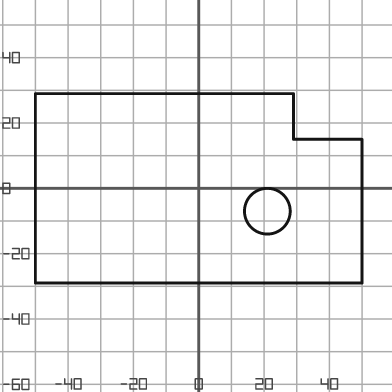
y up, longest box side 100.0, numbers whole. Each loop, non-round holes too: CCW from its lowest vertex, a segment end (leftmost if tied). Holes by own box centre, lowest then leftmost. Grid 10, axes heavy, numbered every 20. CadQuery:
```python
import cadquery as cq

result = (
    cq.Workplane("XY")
    .moveTo(-50.0, -29.0)
    .lineTo(50.0, -29.0)
    .lineTo(50.0, 15.0)
    .lineTo(29.0, 15.0)
    .lineTo(29.0, 29.0)
    .lineTo(-50.0, 29.0)
    .close()
    .moveTo(21.0, -7.0)
    .circle(7.0)
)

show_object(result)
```